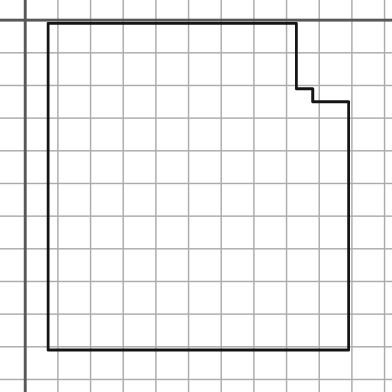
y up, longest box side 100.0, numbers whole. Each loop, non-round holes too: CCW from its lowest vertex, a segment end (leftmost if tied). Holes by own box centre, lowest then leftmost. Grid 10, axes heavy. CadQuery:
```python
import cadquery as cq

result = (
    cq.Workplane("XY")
    .moveTo(7.0, -101.0)
    .lineTo(99.0, -101.0)
    .lineTo(99.0, -25.0)
    .lineTo(88.0, -25.0)
    .lineTo(88.0, -21.0)
    .lineTo(83.0, -21.0)
    .lineTo(83.0, -1.0)
    .lineTo(7.0, -1.0)
    .close()
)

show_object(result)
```